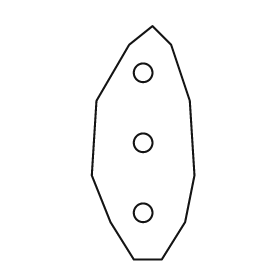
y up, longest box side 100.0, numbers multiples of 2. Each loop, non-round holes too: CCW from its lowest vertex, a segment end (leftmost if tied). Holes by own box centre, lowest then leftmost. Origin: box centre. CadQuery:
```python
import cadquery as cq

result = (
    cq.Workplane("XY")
    .moveTo(-4.0, -50.0)
    .lineTo(8.0, -50.0)
    .lineTo(18.0, -34.0)
    .lineTo(22.0, -14.0)
    .lineTo(20.0, 18.0)
    .lineTo(12.0, 42.0)
    .lineTo(4.0, 50.0)
    .lineTo(-6.0, 42.0)
    .lineTo(-20.0, 18.0)
    .lineTo(-22.0, -14.0)
    .lineTo(-14.0, -34.0)
    .close()
    .moveTo(0.0, -30.0)
    .circle(4.0)
    .moveTo(0.0, 0.0)
    .circle(4.0)
    .moveTo(0.0, 30.0)
    .circle(4.0)
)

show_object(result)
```